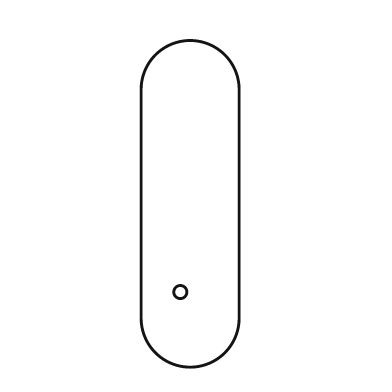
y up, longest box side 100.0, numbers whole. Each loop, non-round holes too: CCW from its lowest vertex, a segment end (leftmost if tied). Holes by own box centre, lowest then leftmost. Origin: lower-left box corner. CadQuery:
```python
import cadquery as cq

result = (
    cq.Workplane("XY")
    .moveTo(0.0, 15.0)
    .threePointArc((15.0, 0.0), (30.0, 15.0))
    .lineTo(30.0, 85.0)
    .threePointArc((15.0, 100.0), (0.0, 85.0))
    .close()
    .moveTo(12.0, 23.0)
    .circle(2.0)
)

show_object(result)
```